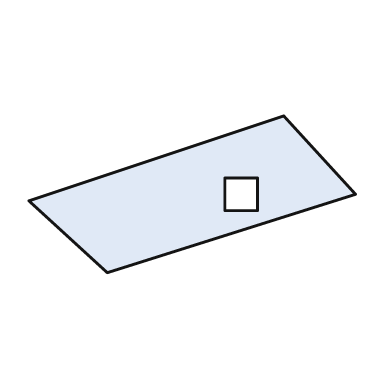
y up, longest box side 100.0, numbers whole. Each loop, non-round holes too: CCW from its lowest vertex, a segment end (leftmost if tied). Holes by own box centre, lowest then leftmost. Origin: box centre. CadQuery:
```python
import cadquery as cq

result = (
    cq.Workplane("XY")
    .moveTo(-26.0, -24.0)
    .lineTo(50.0, 0.0)
    .lineTo(28.0, 24.0)
    .lineTo(-50.0, -2.0)
    .close()
    .moveTo(10.0, -5.0)
    .lineTo(20.0, -5.0)
    .lineTo(20.0, 5.0)
    .lineTo(10.0, 5.0)
    .close()
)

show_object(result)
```